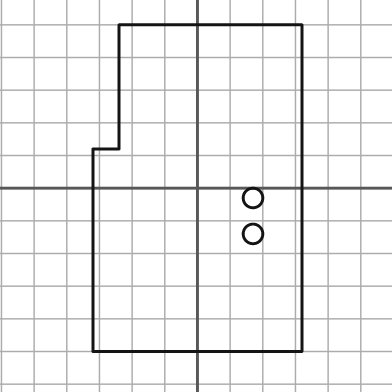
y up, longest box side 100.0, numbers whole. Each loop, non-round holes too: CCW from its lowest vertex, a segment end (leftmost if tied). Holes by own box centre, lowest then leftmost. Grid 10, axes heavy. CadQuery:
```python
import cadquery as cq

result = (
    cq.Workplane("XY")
    .moveTo(-32.0, -50.0)
    .lineTo(32.0, -50.0)
    .lineTo(32.0, 50.0)
    .lineTo(-24.0, 50.0)
    .lineTo(-24.0, 12.0)
    .lineTo(-32.0, 12.0)
    .close()
    .moveTo(17.0, -14.0)
    .circle(3.0)
    .moveTo(17.0, -3.0)
    .circle(3.0)
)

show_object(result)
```